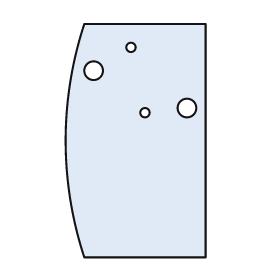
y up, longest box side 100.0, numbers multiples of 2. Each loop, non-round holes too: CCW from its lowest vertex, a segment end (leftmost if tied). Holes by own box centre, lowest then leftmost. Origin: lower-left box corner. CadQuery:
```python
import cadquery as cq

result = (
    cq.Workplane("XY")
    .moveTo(8.0, 0.0)
    .lineTo(60.0, 0.0)
    .lineTo(60.0, 100.0)
    .lineTo(8.0, 100.0)
    .threePointArc((0.0, 50.0), (8.0, 0.0))
    .close()
    .moveTo(34.0, 62.0)
    .circle(2.0)
    .moveTo(52.0, 64.0)
    .circle(4.0)
    .moveTo(12.0, 80.0)
    .circle(4.0)
    .moveTo(28.0, 90.0)
    .circle(2.0)
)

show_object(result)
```